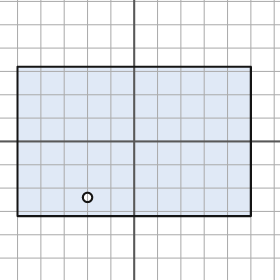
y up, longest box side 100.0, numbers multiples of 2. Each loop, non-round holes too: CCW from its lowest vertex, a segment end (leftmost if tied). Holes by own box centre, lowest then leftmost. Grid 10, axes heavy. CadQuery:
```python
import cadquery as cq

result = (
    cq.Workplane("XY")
    .moveTo(-50.0, -32.0)
    .lineTo(50.0, -32.0)
    .lineTo(50.0, 32.0)
    .lineTo(-50.0, 32.0)
    .close()
    .moveTo(-20.0, -24.0)
    .circle(2.0)
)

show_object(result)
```